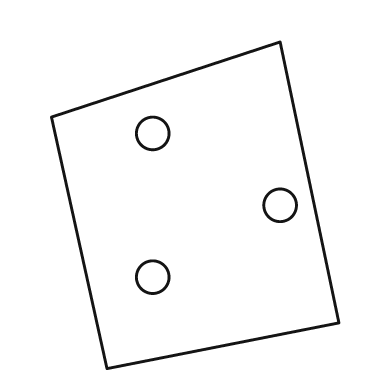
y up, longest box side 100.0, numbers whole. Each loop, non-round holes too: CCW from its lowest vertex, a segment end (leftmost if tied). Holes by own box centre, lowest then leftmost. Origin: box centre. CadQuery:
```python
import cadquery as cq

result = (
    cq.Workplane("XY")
    .moveTo(-27.0, -50.0)
    .lineTo(44.0, -36.0)
    .lineTo(26.0, 50.0)
    .lineTo(-44.0, 27.0)
    .close()
    .moveTo(-13.0, -22.0)
    .circle(5.0)
    .moveTo(26.0, 0.0)
    .circle(5.0)
    .moveTo(-13.0, 22.0)
    .circle(5.0)
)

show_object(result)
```